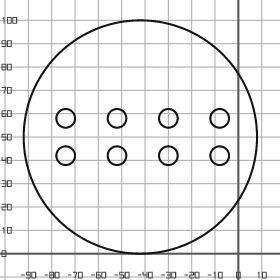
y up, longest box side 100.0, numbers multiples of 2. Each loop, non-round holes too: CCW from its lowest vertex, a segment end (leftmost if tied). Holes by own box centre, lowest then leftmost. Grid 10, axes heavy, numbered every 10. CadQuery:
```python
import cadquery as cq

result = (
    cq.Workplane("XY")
    .moveTo(-42.0, 50.0)
    .circle(50.0)
    .moveTo(-74.0, 42.0)
    .circle(4.0)
    .moveTo(-52.0, 42.0)
    .circle(4.0)
    .moveTo(-30.0, 42.0)
    .circle(4.0)
    .moveTo(-8.0, 42.0)
    .circle(4.0)
    .moveTo(-74.0, 58.0)
    .circle(4.0)
    .moveTo(-52.0, 58.0)
    .circle(4.0)
    .moveTo(-30.0, 58.0)
    .circle(4.0)
    .moveTo(-8.0, 58.0)
    .circle(4.0)
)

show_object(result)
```